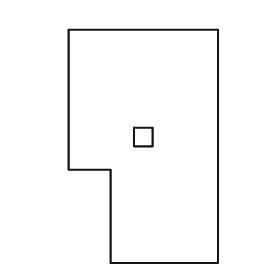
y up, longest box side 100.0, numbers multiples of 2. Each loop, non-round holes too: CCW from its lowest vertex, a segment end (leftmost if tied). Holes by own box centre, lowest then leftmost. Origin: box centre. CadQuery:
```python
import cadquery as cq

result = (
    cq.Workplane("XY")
    .moveTo(-14.0, -50.0)
    .lineTo(32.0, -50.0)
    .lineTo(32.0, 50.0)
    .lineTo(-32.0, 50.0)
    .lineTo(-32.0, -10.0)
    .lineTo(-14.0, -10.0)
    .close()
    .moveTo(-4.0, 0.0)
    .lineTo(4.0, 0.0)
    .lineTo(4.0, 8.0)
    .lineTo(-4.0, 8.0)
    .close()
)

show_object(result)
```